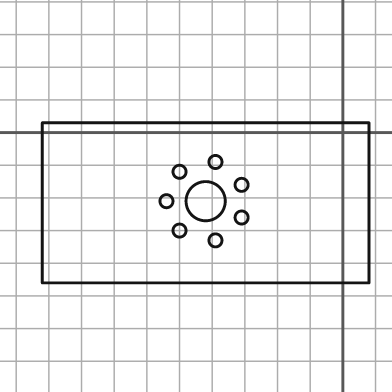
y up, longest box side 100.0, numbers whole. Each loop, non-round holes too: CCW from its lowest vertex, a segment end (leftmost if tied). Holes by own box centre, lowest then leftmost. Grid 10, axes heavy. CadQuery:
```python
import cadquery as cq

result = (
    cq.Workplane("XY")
    .moveTo(-92.0, -46.0)
    .lineTo(8.0, -46.0)
    .lineTo(8.0, 3.0)
    .lineTo(-92.0, 3.0)
    .close()
    .moveTo(-39.0, -33.0)
    .circle(2.0)
    .moveTo(-50.0, -30.0)
    .circle(2.0)
    .moveTo(-31.0, -26.0)
    .circle(2.0)
    .moveTo(-54.0, -21.0)
    .circle(2.0)
    .moveTo(-42.0, -21.0)
    .circle(6.0)
    .moveTo(-31.0, -16.0)
    .circle(2.0)
    .moveTo(-50.0, -12.0)
    .circle(2.0)
    .moveTo(-39.0, -9.0)
    .circle(2.0)
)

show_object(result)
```